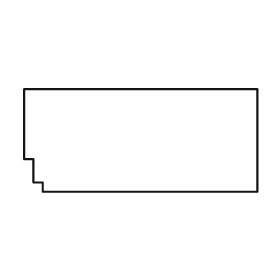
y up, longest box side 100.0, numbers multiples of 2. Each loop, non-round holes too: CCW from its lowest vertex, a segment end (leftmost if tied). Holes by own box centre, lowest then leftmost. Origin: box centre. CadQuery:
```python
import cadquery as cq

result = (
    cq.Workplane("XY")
    .moveTo(-42.0, -22.0)
    .lineTo(50.0, -22.0)
    .lineTo(50.0, 22.0)
    .lineTo(-50.0, 22.0)
    .lineTo(-50.0, -8.0)
    .lineTo(-46.0, -8.0)
    .lineTo(-46.0, -18.0)
    .lineTo(-42.0, -18.0)
    .close()
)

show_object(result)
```